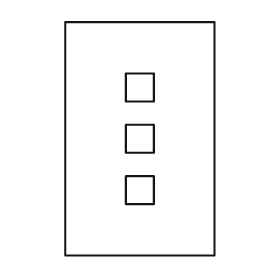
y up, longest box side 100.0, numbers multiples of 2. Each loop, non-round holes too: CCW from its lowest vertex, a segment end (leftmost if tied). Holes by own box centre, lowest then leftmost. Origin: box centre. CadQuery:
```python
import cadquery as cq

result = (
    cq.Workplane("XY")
    .moveTo(-32.0, -50.0)
    .lineTo(32.0, -50.0)
    .lineTo(32.0, 50.0)
    .lineTo(-32.0, 50.0)
    .close()
    .moveTo(-6.0, -28.0)
    .lineTo(6.0, -28.0)
    .lineTo(6.0, -16.0)
    .lineTo(-6.0, -16.0)
    .close()
    .moveTo(-6.0, -6.0)
    .lineTo(6.0, -6.0)
    .lineTo(6.0, 6.0)
    .lineTo(-6.0, 6.0)
    .close()
    .moveTo(-6.0, 16.0)
    .lineTo(6.0, 16.0)
    .lineTo(6.0, 28.0)
    .lineTo(-6.0, 28.0)
    .close()
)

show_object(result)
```